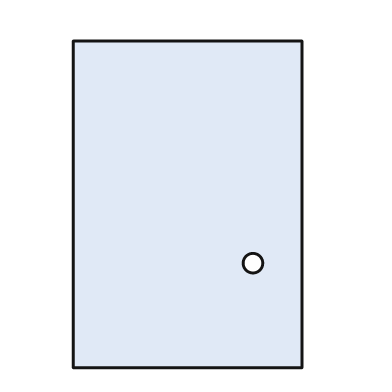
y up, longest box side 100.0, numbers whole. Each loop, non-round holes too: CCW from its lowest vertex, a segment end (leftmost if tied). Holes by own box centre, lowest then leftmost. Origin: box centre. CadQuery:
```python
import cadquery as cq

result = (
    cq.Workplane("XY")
    .moveTo(-35.0, -50.0)
    .lineTo(35.0, -50.0)
    .lineTo(35.0, 50.0)
    .lineTo(-35.0, 50.0)
    .close()
    .moveTo(20.0, -18.0)
    .circle(3.0)
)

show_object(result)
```